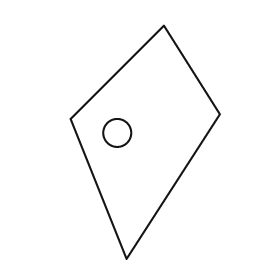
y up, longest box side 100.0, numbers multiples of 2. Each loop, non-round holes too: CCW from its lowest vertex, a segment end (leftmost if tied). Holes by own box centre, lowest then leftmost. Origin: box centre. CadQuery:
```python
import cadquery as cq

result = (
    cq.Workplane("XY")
    .moveTo(-8.0, -50.0)
    .lineTo(32.0, 12.0)
    .lineTo(8.0, 50.0)
    .lineTo(-32.0, 10.0)
    .close()
    .moveTo(-12.0, 4.0)
    .circle(6.0)
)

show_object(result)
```